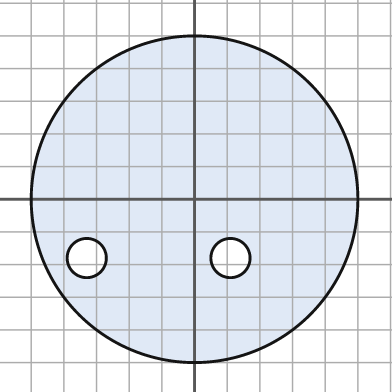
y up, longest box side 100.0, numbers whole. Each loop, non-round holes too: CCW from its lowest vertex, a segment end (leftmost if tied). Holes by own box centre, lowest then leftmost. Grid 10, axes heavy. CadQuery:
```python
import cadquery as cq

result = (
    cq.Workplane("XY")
    .moveTo(0.0, 0.0)
    .circle(50.0)
    .moveTo(-33.0, -18.0)
    .circle(6.0)
    .moveTo(11.0, -18.0)
    .circle(6.0)
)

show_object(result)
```